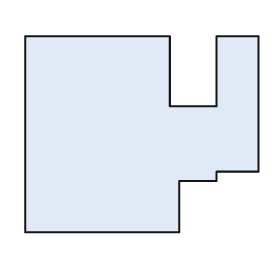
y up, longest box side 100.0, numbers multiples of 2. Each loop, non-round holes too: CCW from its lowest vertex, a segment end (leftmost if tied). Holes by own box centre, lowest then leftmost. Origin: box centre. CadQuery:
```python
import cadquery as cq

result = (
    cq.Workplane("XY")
    .moveTo(-50.0, -42.0)
    .lineTo(16.0, -42.0)
    .lineTo(16.0, -20.0)
    .lineTo(32.0, -20.0)
    .lineTo(32.0, -16.0)
    .lineTo(50.0, -16.0)
    .lineTo(50.0, 42.0)
    .lineTo(32.0, 42.0)
    .lineTo(32.0, 12.0)
    .lineTo(12.0, 12.0)
    .lineTo(12.0, 42.0)
    .lineTo(-50.0, 42.0)
    .close()
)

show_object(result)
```